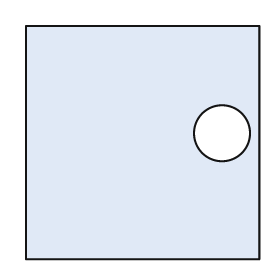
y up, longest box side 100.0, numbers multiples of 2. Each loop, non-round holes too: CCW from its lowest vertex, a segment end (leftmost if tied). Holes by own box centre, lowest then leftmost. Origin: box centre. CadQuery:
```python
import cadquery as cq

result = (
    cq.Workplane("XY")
    .moveTo(-50.0, -50.0)
    .lineTo(50.0, -50.0)
    .lineTo(50.0, 50.0)
    .lineTo(-50.0, 50.0)
    .close()
    .moveTo(34.0, 4.0)
    .circle(12.0)
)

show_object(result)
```